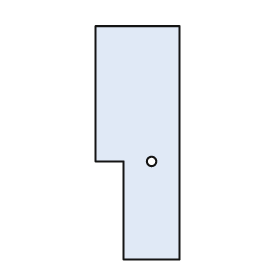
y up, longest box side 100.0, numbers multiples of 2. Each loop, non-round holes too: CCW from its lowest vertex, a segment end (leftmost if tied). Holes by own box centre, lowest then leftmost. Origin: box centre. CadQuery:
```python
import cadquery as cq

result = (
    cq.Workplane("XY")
    .moveTo(-6.0, -50.0)
    .lineTo(18.0, -50.0)
    .lineTo(18.0, 50.0)
    .lineTo(-18.0, 50.0)
    .lineTo(-18.0, -8.0)
    .lineTo(-6.0, -8.0)
    .close()
    .moveTo(6.0, -8.0)
    .circle(2.0)
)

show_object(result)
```